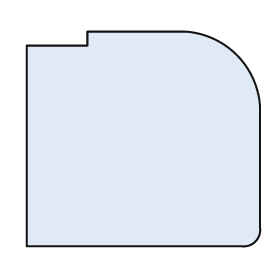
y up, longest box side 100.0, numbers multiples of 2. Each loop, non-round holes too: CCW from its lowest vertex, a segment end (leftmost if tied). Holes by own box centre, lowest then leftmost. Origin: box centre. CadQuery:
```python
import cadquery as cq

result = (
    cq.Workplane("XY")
    .moveTo(-50.0, -46.0)
    .lineTo(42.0, -46.0)
    .threePointArc((48.0, -44.0), (50.0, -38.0))
    .lineTo(50.0, 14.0)
    .threePointArc((40.0, 36.0), (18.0, 46.0))
    .lineTo(-24.0, 46.0)
    .lineTo(-24.0, 40.0)
    .lineTo(-50.0, 40.0)
    .close()
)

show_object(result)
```